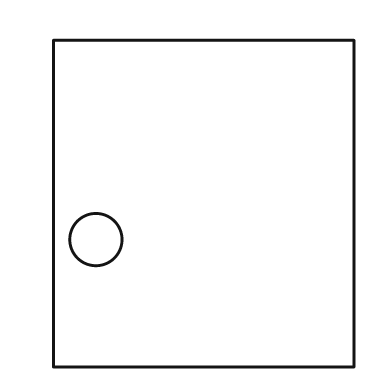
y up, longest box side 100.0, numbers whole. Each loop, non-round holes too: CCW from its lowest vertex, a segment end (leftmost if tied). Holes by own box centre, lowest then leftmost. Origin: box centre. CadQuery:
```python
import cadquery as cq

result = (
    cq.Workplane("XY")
    .moveTo(-46.0, -50.0)
    .lineTo(46.0, -50.0)
    .lineTo(46.0, 50.0)
    .lineTo(-46.0, 50.0)
    .close()
    .moveTo(-33.0, -11.0)
    .circle(8.0)
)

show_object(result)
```